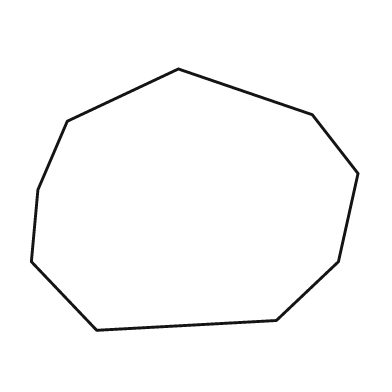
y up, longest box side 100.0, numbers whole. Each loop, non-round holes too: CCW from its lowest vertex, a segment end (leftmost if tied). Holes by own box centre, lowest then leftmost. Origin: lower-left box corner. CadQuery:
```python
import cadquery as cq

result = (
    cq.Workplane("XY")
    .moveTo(20.0, 0.0)
    .lineTo(75.0, 3.0)
    .lineTo(94.0, 21.0)
    .lineTo(100.0, 48.0)
    .lineTo(86.0, 66.0)
    .lineTo(45.0, 80.0)
    .lineTo(11.0, 64.0)
    .lineTo(2.0, 43.0)
    .lineTo(0.0, 21.0)
    .close()
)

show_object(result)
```